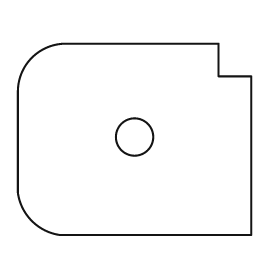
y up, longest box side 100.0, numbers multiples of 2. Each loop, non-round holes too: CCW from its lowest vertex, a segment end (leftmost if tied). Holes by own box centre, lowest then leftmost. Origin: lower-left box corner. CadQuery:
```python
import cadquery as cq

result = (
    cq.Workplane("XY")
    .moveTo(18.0, 0.0)
    .lineTo(100.0, 0.0)
    .lineTo(100.0, 68.0)
    .lineTo(86.0, 68.0)
    .lineTo(86.0, 82.0)
    .lineTo(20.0, 82.0)
    .threePointArc((6.0, 76.0), (0.0, 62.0))
    .lineTo(0.0, 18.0)
    .threePointArc((6.0, 6.0), (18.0, 0.0))
    .close()
    .moveTo(50.0, 42.0)
    .circle(8.0)
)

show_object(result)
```